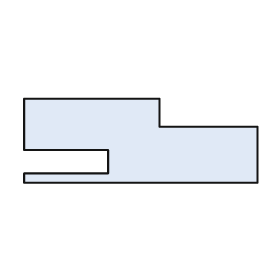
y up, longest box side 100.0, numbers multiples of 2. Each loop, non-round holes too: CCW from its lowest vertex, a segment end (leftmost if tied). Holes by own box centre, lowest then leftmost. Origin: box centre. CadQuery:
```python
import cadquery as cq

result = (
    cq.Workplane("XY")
    .moveTo(-50.0, -18.0)
    .lineTo(50.0, -18.0)
    .lineTo(50.0, 6.0)
    .lineTo(8.0, 6.0)
    .lineTo(8.0, 18.0)
    .lineTo(-50.0, 18.0)
    .lineTo(-50.0, -4.0)
    .lineTo(-14.0, -4.0)
    .lineTo(-14.0, -14.0)
    .lineTo(-50.0, -14.0)
    .close()
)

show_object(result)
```